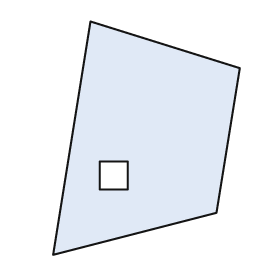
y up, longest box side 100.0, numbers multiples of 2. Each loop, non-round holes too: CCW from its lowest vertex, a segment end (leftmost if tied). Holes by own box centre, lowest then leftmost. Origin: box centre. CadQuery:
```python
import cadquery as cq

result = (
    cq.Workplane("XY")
    .moveTo(-40.0, -50.0)
    .lineTo(30.0, -32.0)
    .lineTo(40.0, 30.0)
    .lineTo(-24.0, 50.0)
    .close()
    .moveTo(-20.0, -22.0)
    .lineTo(-8.0, -22.0)
    .lineTo(-8.0, -10.0)
    .lineTo(-20.0, -10.0)
    .close()
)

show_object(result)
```